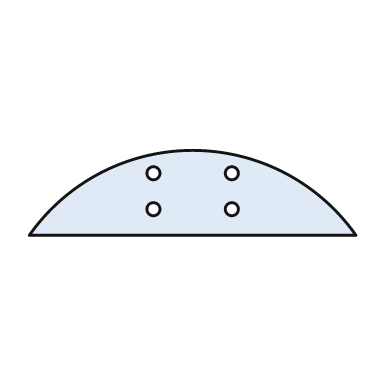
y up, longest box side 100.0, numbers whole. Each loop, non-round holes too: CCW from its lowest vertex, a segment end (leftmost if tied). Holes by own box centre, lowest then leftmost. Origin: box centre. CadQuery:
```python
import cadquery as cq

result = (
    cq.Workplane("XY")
    .moveTo(-50.0, -13.0)
    .lineTo(50.0, -13.0)
    .threePointArc((0.0, 13.0), (-50.0, -13.0))
    .close()
    .moveTo(-12.0, -5.0)
    .circle(2.0)
    .moveTo(12.0, -5.0)
    .circle(2.0)
    .moveTo(-12.0, 6.0)
    .circle(2.0)
    .moveTo(12.0, 6.0)
    .circle(2.0)
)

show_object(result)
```